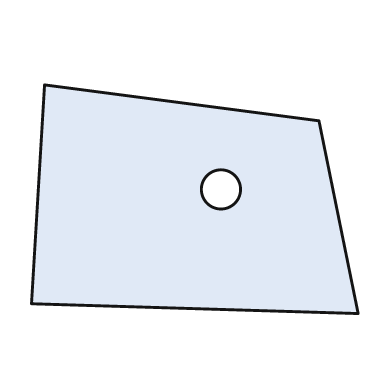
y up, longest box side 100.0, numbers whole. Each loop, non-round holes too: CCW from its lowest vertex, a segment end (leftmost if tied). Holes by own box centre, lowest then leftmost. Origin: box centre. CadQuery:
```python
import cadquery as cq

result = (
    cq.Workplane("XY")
    .moveTo(50.0, -35.0)
    .lineTo(38.0, 24.0)
    .lineTo(-46.0, 35.0)
    .lineTo(-50.0, -32.0)
    .close()
    .moveTo(8.0, 3.0)
    .circle(6.0)
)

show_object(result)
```